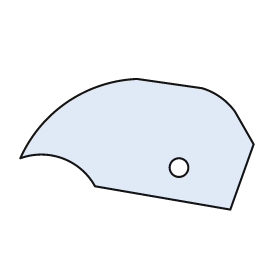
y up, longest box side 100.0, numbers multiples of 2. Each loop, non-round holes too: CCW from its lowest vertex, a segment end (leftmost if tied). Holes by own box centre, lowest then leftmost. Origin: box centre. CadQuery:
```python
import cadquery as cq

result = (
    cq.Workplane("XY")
    .moveTo(40.0, -28.0)
    .lineTo(50.0, 0.0)
    .lineTo(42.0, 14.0)
    .threePointArc((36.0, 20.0), (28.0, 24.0))
    .lineTo(0.0, 28.0)
    .threePointArc((-30.0, 18.0), (-50.0, -6.0))
    .threePointArc((-32.0, -6.0), (-18.0, -18.0))
    .close()
    .moveTo(18.0, -10.0)
    .circle(4.0)
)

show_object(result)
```